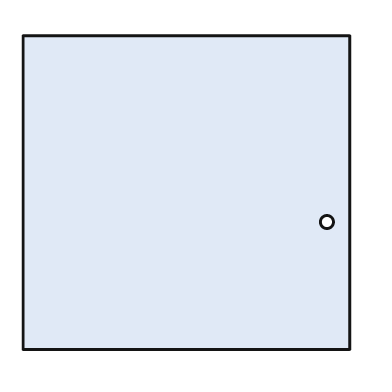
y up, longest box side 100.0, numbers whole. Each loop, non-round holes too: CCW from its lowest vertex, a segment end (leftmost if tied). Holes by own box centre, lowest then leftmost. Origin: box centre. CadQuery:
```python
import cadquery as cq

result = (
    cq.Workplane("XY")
    .moveTo(-50.0, -48.0)
    .lineTo(50.0, -48.0)
    .lineTo(50.0, 48.0)
    .lineTo(-50.0, 48.0)
    .close()
    .moveTo(43.0, -9.0)
    .circle(2.0)
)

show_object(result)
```